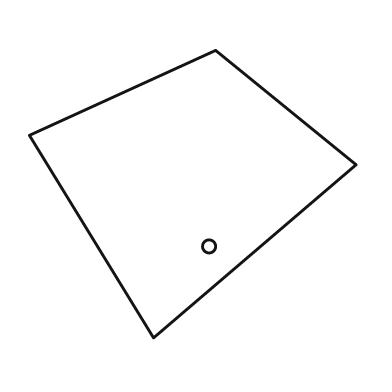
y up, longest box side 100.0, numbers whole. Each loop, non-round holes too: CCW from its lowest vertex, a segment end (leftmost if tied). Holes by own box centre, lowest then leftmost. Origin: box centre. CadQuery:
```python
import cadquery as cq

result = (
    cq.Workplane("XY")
    .moveTo(-12.0, -44.0)
    .lineTo(50.0, 9.0)
    .lineTo(7.0, 44.0)
    .lineTo(-50.0, 18.0)
    .close()
    .moveTo(5.0, -16.0)
    .circle(2.0)
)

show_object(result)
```